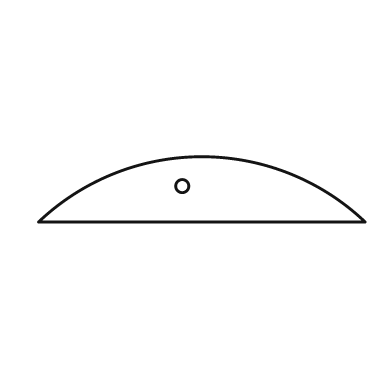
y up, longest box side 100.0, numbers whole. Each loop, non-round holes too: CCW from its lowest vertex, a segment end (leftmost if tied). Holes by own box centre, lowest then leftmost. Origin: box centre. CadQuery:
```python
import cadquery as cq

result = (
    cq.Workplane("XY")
    .moveTo(-50.0, -10.0)
    .lineTo(50.0, -10.0)
    .threePointArc((0.0, 10.0), (-50.0, -10.0))
    .close()
    .moveTo(-6.0, 1.0)
    .circle(2.0)
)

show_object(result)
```